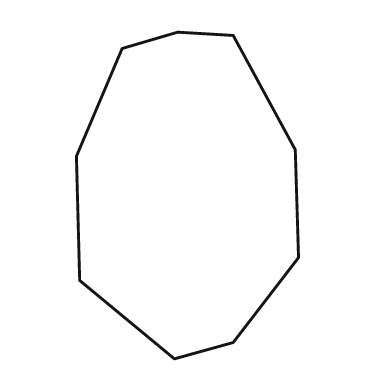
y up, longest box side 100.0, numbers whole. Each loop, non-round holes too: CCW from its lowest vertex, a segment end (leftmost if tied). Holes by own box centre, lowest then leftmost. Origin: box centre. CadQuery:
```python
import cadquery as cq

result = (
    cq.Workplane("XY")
    .moveTo(-4.0, -50.0)
    .lineTo(14.0, -45.0)
    .lineTo(34.0, -19.0)
    .lineTo(33.0, 14.0)
    .lineTo(14.0, 49.0)
    .lineTo(-3.0, 50.0)
    .lineTo(-20.0, 45.0)
    .lineTo(-34.0, 12.0)
    .lineTo(-33.0, -26.0)
    .close()
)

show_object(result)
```